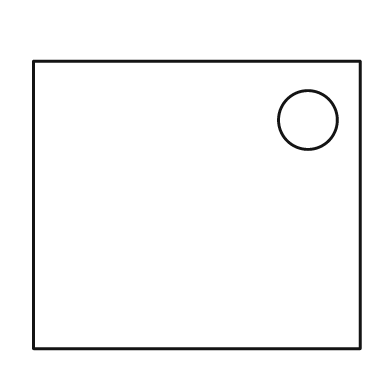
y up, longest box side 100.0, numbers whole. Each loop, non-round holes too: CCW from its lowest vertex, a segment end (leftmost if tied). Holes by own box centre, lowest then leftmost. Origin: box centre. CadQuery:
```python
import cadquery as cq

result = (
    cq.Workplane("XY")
    .moveTo(-50.0, -44.0)
    .lineTo(50.0, -44.0)
    .lineTo(50.0, 44.0)
    .lineTo(-50.0, 44.0)
    .close()
    .moveTo(34.0, 26.0)
    .circle(9.0)
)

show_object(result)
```